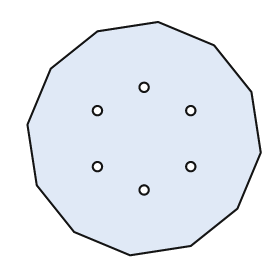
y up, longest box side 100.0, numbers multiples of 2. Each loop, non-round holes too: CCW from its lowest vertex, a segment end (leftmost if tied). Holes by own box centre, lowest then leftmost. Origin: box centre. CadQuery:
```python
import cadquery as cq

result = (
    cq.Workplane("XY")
    .moveTo(-6.0, -50.0)
    .lineTo(20.0, -46.0)
    .lineTo(40.0, -30.0)
    .lineTo(50.0, -6.0)
    .lineTo(46.0, 20.0)
    .lineTo(30.0, 40.0)
    .lineTo(6.0, 50.0)
    .lineTo(-20.0, 46.0)
    .lineTo(-40.0, 30.0)
    .lineTo(-50.0, 6.0)
    .lineTo(-46.0, -20.0)
    .lineTo(-30.0, -40.0)
    .close()
    .moveTo(0.0, -22.0)
    .circle(2.0)
    .moveTo(-20.0, -12.0)
    .circle(2.0)
    .moveTo(20.0, -12.0)
    .circle(2.0)
    .moveTo(-20.0, 12.0)
    .circle(2.0)
    .moveTo(20.0, 12.0)
    .circle(2.0)
    .moveTo(0.0, 22.0)
    .circle(2.0)
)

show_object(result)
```